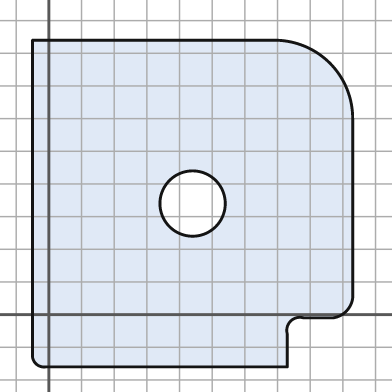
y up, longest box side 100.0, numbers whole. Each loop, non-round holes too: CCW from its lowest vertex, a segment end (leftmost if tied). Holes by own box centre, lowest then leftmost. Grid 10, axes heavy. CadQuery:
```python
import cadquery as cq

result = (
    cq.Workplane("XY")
    .moveTo(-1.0, -16.0)
    .lineTo(73.0, -16.0)
    .lineTo(73.0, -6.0)
    .threePointArc((74.0, -2.0), (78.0, -1.0))
    .lineTo(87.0, -1.0)
    .threePointArc((91.0, 1.0), (93.0, 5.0))
    .lineTo(93.0, 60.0)
    .threePointArc((86.0, 77.0), (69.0, 84.0))
    .lineTo(-5.0, 84.0)
    .lineTo(-5.0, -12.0)
    .threePointArc((-4.0, -15.0), (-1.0, -16.0))
    .close()
    .moveTo(44.0, 34.0)
    .circle(10.0)
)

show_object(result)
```